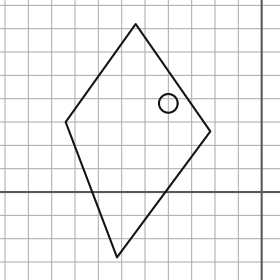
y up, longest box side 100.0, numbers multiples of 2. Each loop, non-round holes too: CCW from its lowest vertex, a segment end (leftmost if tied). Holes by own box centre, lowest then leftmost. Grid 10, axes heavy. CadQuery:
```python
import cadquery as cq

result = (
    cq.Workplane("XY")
    .moveTo(-62.0, -28.0)
    .lineTo(-22.0, 26.0)
    .lineTo(-54.0, 72.0)
    .lineTo(-84.0, 30.0)
    .close()
    .moveTo(-40.0, 38.0)
    .circle(4.0)
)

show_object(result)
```